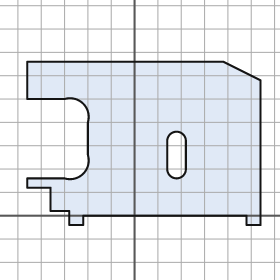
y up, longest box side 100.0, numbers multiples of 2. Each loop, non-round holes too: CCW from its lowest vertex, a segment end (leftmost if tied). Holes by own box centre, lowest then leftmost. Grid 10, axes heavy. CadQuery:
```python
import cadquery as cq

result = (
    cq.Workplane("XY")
    .moveTo(-28.0, -4.0)
    .lineTo(-22.0, -4.0)
    .lineTo(-22.0, 0.0)
    .lineTo(48.0, 0.0)
    .lineTo(48.0, -4.0)
    .lineTo(54.0, -4.0)
    .lineTo(54.0, 58.0)
    .lineTo(38.0, 66.0)
    .lineTo(-46.0, 66.0)
    .lineTo(-46.0, 50.0)
    .lineTo(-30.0, 50.0)
    .threePointArc((-22.0, 48.0), (-20.0, 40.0))
    .lineTo(-20.0, 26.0)
    .threePointArc((-22.0, 18.0), (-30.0, 16.0))
    .lineTo(-46.0, 16.0)
    .lineTo(-46.0, 12.0)
    .lineTo(-36.0, 12.0)
    .lineTo(-36.0, 2.0)
    .lineTo(-28.0, 2.0)
    .close()
    .moveTo(14.0, 20.0)
    .threePointArc((18.0, 16.0), (22.0, 20.0))
    .lineTo(22.0, 32.0)
    .threePointArc((18.0, 36.0), (14.0, 32.0))
    .close()
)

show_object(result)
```